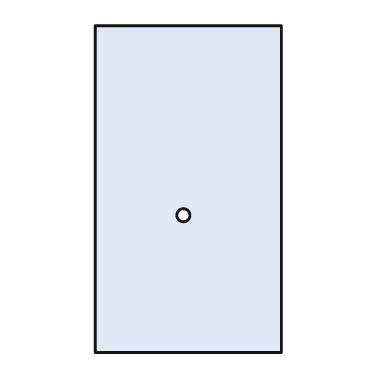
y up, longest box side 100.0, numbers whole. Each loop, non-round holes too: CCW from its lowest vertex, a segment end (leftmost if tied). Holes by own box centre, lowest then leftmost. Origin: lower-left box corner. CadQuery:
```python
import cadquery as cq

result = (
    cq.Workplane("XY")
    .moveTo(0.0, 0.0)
    .lineTo(57.0, 0.0)
    .lineTo(57.0, 100.0)
    .lineTo(0.0, 100.0)
    .close()
    .moveTo(27.0, 42.0)
    .circle(2.0)
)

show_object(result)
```